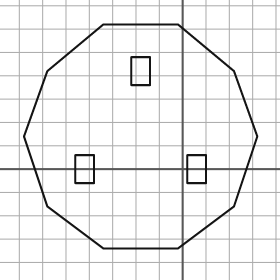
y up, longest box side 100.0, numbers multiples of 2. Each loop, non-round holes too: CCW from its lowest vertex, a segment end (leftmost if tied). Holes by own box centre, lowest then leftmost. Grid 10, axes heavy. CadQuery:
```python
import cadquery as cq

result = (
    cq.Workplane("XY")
    .moveTo(-34.0, -34.0)
    .lineTo(-2.0, -34.0)
    .lineTo(22.0, -16.0)
    .lineTo(32.0, 14.0)
    .lineTo(22.0, 42.0)
    .lineTo(-2.0, 62.0)
    .lineTo(-34.0, 62.0)
    .lineTo(-58.0, 42.0)
    .lineTo(-68.0, 14.0)
    .lineTo(-58.0, -16.0)
    .close()
    .moveTo(-46.0, -6.0)
    .lineTo(-38.0, -6.0)
    .lineTo(-38.0, 6.0)
    .lineTo(-46.0, 6.0)
    .close()
    .moveTo(2.0, -6.0)
    .lineTo(10.0, -6.0)
    .lineTo(10.0, 6.0)
    .lineTo(2.0, 6.0)
    .close()
    .moveTo(-22.0, 36.0)
    .lineTo(-14.0, 36.0)
    .lineTo(-14.0, 48.0)
    .lineTo(-22.0, 48.0)
    .close()
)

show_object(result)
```